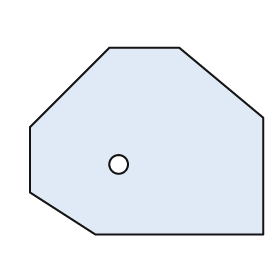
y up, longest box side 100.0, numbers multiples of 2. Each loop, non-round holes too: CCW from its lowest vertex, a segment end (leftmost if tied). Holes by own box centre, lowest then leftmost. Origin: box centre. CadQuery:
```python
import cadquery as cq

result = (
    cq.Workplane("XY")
    .moveTo(-22.0, -40.0)
    .lineTo(50.0, -40.0)
    .lineTo(50.0, 10.0)
    .lineTo(14.0, 40.0)
    .lineTo(-16.0, 40.0)
    .lineTo(-50.0, 6.0)
    .lineTo(-50.0, -22.0)
    .close()
    .moveTo(-12.0, -10.0)
    .circle(4.0)
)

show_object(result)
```